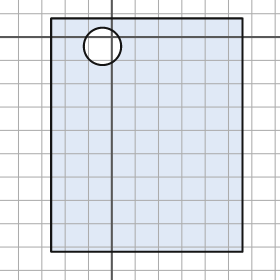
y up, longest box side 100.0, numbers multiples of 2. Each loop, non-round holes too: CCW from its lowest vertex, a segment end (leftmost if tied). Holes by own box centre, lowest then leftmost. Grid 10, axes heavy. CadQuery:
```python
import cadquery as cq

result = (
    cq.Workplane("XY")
    .moveTo(-26.0, -92.0)
    .lineTo(56.0, -92.0)
    .lineTo(56.0, 8.0)
    .lineTo(-26.0, 8.0)
    .close()
    .moveTo(-4.0, -4.0)
    .circle(8.0)
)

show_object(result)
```